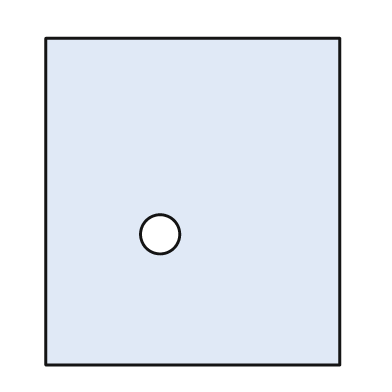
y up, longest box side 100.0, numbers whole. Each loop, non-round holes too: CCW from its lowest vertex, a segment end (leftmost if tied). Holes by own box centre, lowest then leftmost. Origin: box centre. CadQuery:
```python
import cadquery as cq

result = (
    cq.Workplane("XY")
    .moveTo(-45.0, -50.0)
    .lineTo(45.0, -50.0)
    .lineTo(45.0, 50.0)
    .lineTo(-45.0, 50.0)
    .close()
    .moveTo(-10.0, -10.0)
    .circle(6.0)
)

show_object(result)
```